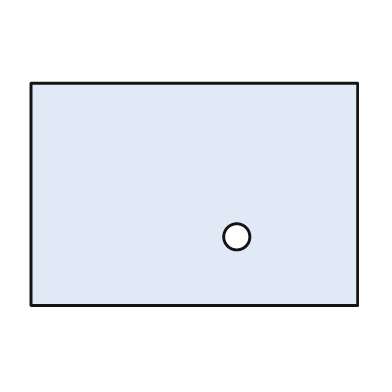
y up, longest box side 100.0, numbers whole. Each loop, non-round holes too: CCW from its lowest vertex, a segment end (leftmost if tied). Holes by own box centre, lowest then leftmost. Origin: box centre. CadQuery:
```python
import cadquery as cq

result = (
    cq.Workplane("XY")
    .moveTo(-50.0, -34.0)
    .lineTo(50.0, -34.0)
    .lineTo(50.0, 34.0)
    .lineTo(-50.0, 34.0)
    .close()
    .moveTo(13.0, -13.0)
    .circle(4.0)
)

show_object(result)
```